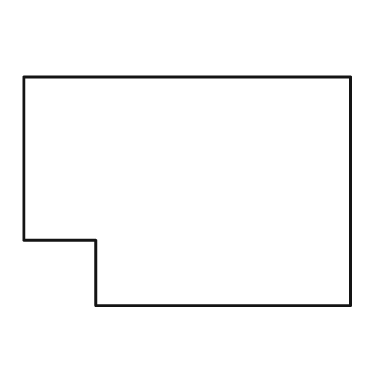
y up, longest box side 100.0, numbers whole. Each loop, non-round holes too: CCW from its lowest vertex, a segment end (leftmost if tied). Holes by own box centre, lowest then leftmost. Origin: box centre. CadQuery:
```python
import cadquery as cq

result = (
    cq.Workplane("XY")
    .moveTo(-28.0, -35.0)
    .lineTo(50.0, -35.0)
    .lineTo(50.0, 35.0)
    .lineTo(-50.0, 35.0)
    .lineTo(-50.0, -15.0)
    .lineTo(-28.0, -15.0)
    .close()
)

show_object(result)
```